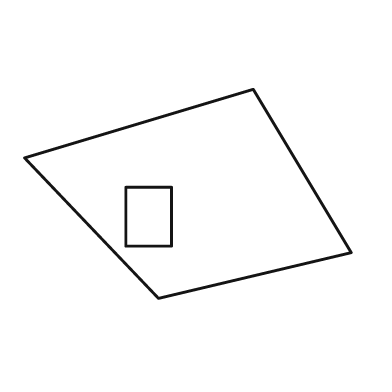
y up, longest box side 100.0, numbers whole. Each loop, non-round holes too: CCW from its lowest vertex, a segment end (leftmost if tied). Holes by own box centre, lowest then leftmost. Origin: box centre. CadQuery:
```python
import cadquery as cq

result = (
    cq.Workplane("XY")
    .moveTo(-9.0, -32.0)
    .lineTo(50.0, -18.0)
    .lineTo(20.0, 32.0)
    .lineTo(-50.0, 11.0)
    .close()
    .moveTo(-19.0, -16.0)
    .lineTo(-5.0, -16.0)
    .lineTo(-5.0, 2.0)
    .lineTo(-19.0, 2.0)
    .close()
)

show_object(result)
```